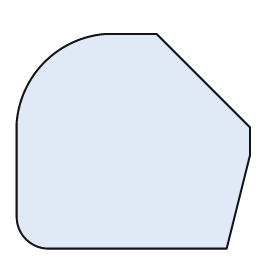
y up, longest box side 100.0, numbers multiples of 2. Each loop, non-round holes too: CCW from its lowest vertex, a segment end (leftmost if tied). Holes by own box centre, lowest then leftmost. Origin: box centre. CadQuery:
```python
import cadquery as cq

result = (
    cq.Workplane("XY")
    .moveTo(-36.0, -46.0)
    .lineTo(40.0, -46.0)
    .lineTo(50.0, -6.0)
    .lineTo(50.0, 6.0)
    .lineTo(10.0, 46.0)
    .lineTo(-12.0, 46.0)
    .threePointArc((-38.0, 34.0), (-50.0, 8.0))
    .lineTo(-50.0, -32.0)
    .threePointArc((-46.0, -42.0), (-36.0, -46.0))
    .close()
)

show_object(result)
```